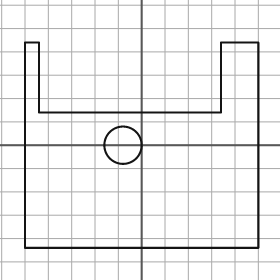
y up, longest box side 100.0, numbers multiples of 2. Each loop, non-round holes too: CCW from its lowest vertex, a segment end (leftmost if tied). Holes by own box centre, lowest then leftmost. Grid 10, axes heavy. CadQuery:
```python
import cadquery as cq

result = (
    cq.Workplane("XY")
    .moveTo(-50.0, -44.0)
    .lineTo(50.0, -44.0)
    .lineTo(50.0, 44.0)
    .lineTo(34.0, 44.0)
    .lineTo(34.0, 14.0)
    .lineTo(-44.0, 14.0)
    .lineTo(-44.0, 44.0)
    .lineTo(-50.0, 44.0)
    .close()
    .moveTo(-8.0, 0.0)
    .circle(8.0)
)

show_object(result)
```